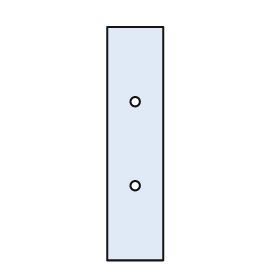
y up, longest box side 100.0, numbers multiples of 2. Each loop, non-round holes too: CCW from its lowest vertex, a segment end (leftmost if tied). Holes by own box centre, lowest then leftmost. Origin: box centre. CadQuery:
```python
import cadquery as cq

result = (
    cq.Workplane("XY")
    .moveTo(-12.0, -50.0)
    .lineTo(12.0, -50.0)
    .lineTo(12.0, 50.0)
    .lineTo(-12.0, 50.0)
    .close()
    .moveTo(0.0, -18.0)
    .circle(2.0)
    .moveTo(0.0, 18.0)
    .circle(2.0)
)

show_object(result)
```